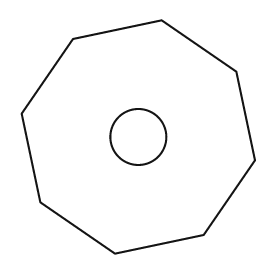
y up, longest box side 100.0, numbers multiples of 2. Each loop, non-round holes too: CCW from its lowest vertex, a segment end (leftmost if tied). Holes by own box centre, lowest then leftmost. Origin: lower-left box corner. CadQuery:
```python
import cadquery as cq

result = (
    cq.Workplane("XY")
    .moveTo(40.0, 0.0)
    .lineTo(78.0, 8.0)
    .lineTo(100.0, 40.0)
    .lineTo(92.0, 78.0)
    .lineTo(60.0, 100.0)
    .lineTo(22.0, 92.0)
    .lineTo(0.0, 60.0)
    .lineTo(8.0, 22.0)
    .close()
    .moveTo(50.0, 50.0)
    .circle(12.0)
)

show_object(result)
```